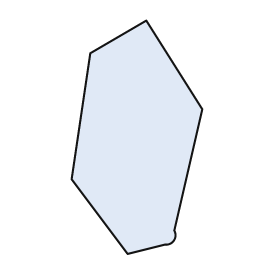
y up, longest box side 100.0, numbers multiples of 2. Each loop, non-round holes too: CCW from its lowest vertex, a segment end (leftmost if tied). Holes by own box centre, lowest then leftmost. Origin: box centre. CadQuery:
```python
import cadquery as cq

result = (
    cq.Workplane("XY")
    .moveTo(-4.0, -50.0)
    .lineTo(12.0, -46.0)
    .threePointArc((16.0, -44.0), (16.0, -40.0))
    .lineTo(28.0, 12.0)
    .lineTo(4.0, 50.0)
    .lineTo(-20.0, 36.0)
    .lineTo(-28.0, -18.0)
    .close()
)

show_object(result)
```